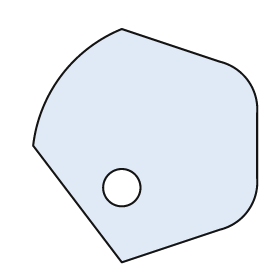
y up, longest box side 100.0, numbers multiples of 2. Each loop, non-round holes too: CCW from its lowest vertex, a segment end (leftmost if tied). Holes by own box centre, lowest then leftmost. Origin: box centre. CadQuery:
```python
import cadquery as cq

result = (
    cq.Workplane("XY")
    .moveTo(-10.0, -50.0)
    .lineTo(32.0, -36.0)
    .threePointArc((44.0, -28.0), (48.0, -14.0))
    .lineTo(48.0, 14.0)
    .threePointArc((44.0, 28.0), (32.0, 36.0))
    .lineTo(-10.0, 50.0)
    .threePointArc((-36.0, 30.0), (-48.0, 0.0))
    .close()
    .moveTo(-10.0, -18.0)
    .circle(8.0)
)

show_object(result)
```